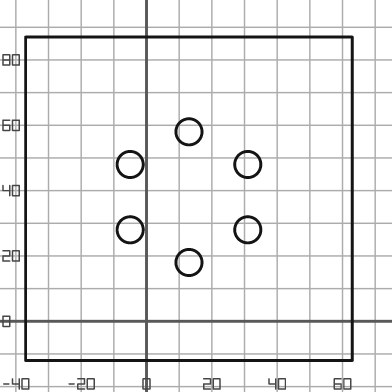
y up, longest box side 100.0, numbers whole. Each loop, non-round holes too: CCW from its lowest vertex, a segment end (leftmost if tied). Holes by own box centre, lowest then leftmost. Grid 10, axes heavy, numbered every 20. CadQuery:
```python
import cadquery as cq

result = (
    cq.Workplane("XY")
    .moveTo(-37.0, -12.0)
    .lineTo(63.0, -12.0)
    .lineTo(63.0, 87.0)
    .lineTo(-37.0, 87.0)
    .close()
    .moveTo(13.0, 18.0)
    .circle(4.0)
    .moveTo(-5.0, 28.0)
    .circle(4.0)
    .moveTo(31.0, 28.0)
    .circle(4.0)
    .moveTo(-5.0, 48.0)
    .circle(4.0)
    .moveTo(31.0, 48.0)
    .circle(4.0)
    .moveTo(13.0, 58.0)
    .circle(4.0)
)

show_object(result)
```